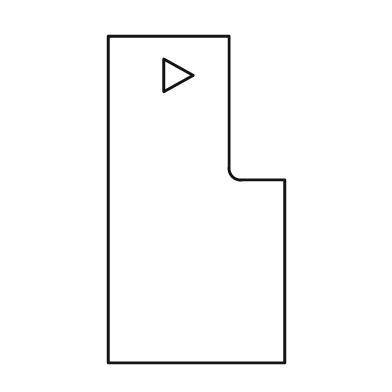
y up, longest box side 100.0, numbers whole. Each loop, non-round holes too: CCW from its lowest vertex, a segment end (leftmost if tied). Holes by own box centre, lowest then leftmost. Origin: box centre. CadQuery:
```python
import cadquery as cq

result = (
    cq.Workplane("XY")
    .moveTo(-27.0, -50.0)
    .lineTo(27.0, -50.0)
    .lineTo(27.0, 6.0)
    .lineTo(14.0, 6.0)
    .threePointArc((11.0, 7.0), (10.0, 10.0))
    .lineTo(10.0, 50.0)
    .lineTo(-27.0, 50.0)
    .close()
    .moveTo(-10.0, 33.0)
    .lineTo(-1.0, 38.0)
    .lineTo(-10.0, 43.0)
    .close()
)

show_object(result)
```